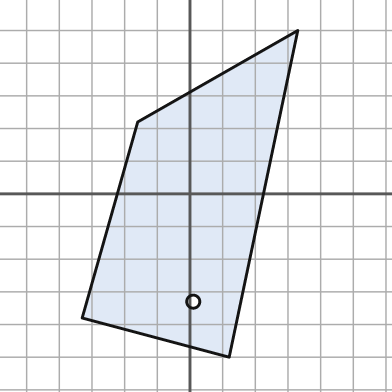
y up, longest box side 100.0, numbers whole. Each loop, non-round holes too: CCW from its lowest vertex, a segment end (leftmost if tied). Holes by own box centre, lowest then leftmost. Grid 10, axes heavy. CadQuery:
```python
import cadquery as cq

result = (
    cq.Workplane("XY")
    .moveTo(12.0, -50.0)
    .lineTo(33.0, 50.0)
    .lineTo(-16.0, 22.0)
    .lineTo(-33.0, -38.0)
    .close()
    .moveTo(1.0, -33.0)
    .circle(2.0)
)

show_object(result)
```